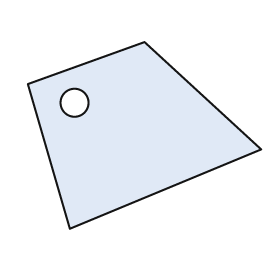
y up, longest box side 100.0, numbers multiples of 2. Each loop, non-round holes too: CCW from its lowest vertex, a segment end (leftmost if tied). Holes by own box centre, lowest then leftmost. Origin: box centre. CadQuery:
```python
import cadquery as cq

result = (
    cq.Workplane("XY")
    .moveTo(-32.0, -40.0)
    .lineTo(50.0, -6.0)
    .lineTo(0.0, 40.0)
    .lineTo(-50.0, 22.0)
    .close()
    .moveTo(-30.0, 14.0)
    .circle(6.0)
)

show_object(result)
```